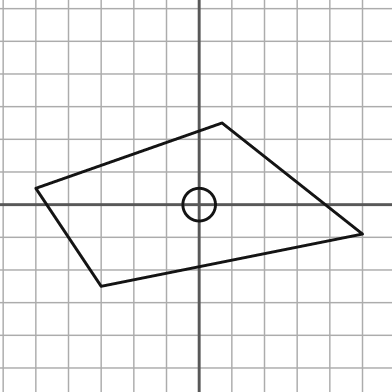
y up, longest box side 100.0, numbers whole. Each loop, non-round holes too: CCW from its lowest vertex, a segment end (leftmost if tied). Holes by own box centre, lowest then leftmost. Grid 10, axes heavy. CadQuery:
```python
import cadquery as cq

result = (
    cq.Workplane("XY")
    .moveTo(-30.0, -25.0)
    .lineTo(50.0, -9.0)
    .lineTo(7.0, 25.0)
    .lineTo(-50.0, 5.0)
    .close()
    .moveTo(0.0, 0.0)
    .circle(5.0)
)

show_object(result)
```